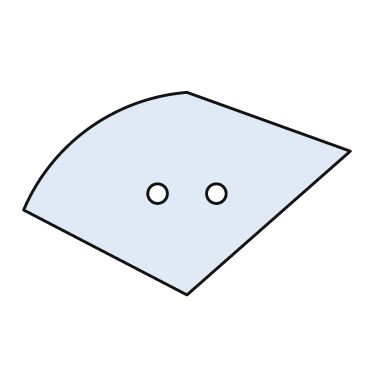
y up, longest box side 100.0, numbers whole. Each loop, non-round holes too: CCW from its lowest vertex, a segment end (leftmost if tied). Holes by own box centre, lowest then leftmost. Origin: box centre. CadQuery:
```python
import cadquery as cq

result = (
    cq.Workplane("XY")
    .moveTo(0.0, -31.0)
    .lineTo(50.0, 13.0)
    .lineTo(0.0, 31.0)
    .threePointArc((-30.0, 20.0), (-50.0, -5.0))
    .close()
    .moveTo(-9.0, 0.0)
    .circle(3.0)
    .moveTo(9.0, 0.0)
    .circle(3.0)
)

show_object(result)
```